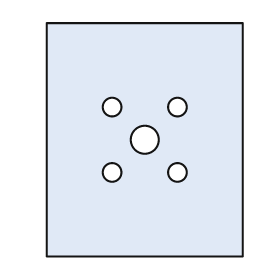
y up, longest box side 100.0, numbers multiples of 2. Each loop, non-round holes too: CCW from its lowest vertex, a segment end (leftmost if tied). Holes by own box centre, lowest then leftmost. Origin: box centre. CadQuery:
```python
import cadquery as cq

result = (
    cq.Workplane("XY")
    .moveTo(-42.0, -50.0)
    .lineTo(42.0, -50.0)
    .lineTo(42.0, 50.0)
    .lineTo(-42.0, 50.0)
    .close()
    .moveTo(-14.0, -14.0)
    .circle(4.0)
    .moveTo(14.0, -14.0)
    .circle(4.0)
    .moveTo(0.0, 0.0)
    .circle(6.0)
    .moveTo(-14.0, 14.0)
    .circle(4.0)
    .moveTo(14.0, 14.0)
    .circle(4.0)
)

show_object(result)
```